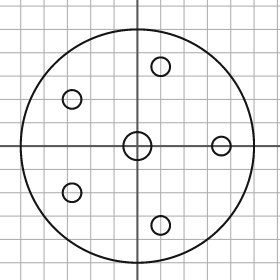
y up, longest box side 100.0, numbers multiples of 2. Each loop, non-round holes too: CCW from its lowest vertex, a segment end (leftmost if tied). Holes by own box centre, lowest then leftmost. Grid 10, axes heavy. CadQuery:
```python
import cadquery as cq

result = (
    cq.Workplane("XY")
    .moveTo(0.0, 0.0)
    .circle(50.0)
    .moveTo(10.0, -34.0)
    .circle(4.0)
    .moveTo(-28.0, -20.0)
    .circle(4.0)
    .moveTo(0.0, 0.0)
    .circle(6.0)
    .moveTo(36.0, 0.0)
    .circle(4.0)
    .moveTo(-28.0, 20.0)
    .circle(4.0)
    .moveTo(10.0, 34.0)
    .circle(4.0)
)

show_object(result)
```